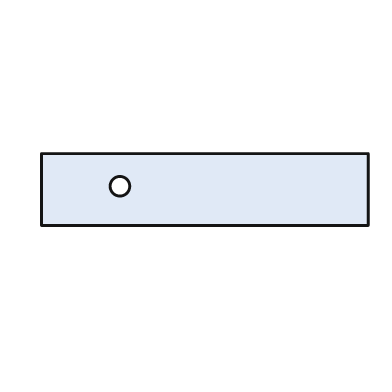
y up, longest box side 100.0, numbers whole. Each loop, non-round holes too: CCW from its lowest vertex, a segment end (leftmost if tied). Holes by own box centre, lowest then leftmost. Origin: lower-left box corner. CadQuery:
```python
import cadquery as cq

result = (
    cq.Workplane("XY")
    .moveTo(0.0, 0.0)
    .lineTo(100.0, 0.0)
    .lineTo(100.0, 22.0)
    .lineTo(0.0, 22.0)
    .close()
    .moveTo(24.0, 12.0)
    .circle(3.0)
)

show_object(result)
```